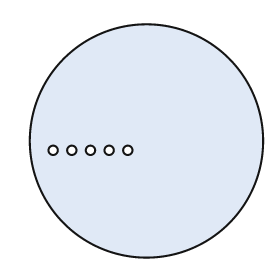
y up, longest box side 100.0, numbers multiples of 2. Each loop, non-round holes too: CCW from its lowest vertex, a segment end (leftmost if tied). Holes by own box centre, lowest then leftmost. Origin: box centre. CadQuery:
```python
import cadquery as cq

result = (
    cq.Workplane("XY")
    .moveTo(0.0, 0.0)
    .circle(50.0)
    .moveTo(-40.0, -4.0)
    .circle(2.0)
    .moveTo(-32.0, -4.0)
    .circle(2.0)
    .moveTo(-24.0, -4.0)
    .circle(2.0)
    .moveTo(-16.0, -4.0)
    .circle(2.0)
    .moveTo(-8.0, -4.0)
    .circle(2.0)
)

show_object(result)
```